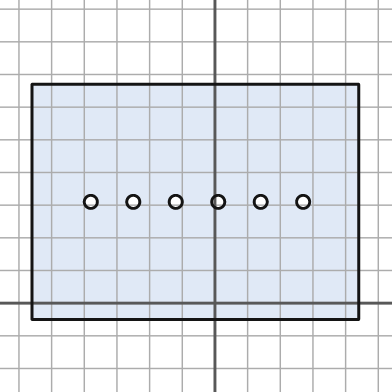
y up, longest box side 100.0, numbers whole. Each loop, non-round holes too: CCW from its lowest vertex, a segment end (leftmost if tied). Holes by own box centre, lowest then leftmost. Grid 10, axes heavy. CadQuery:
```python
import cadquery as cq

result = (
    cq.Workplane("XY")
    .moveTo(-56.0, -5.0)
    .lineTo(44.0, -5.0)
    .lineTo(44.0, 67.0)
    .lineTo(-56.0, 67.0)
    .close()
    .moveTo(-38.0, 31.0)
    .circle(2.0)
    .moveTo(-25.0, 31.0)
    .circle(2.0)
    .moveTo(-12.0, 31.0)
    .circle(2.0)
    .moveTo(1.0, 31.0)
    .circle(2.0)
    .moveTo(14.0, 31.0)
    .circle(2.0)
    .moveTo(27.0, 31.0)
    .circle(2.0)
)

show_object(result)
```